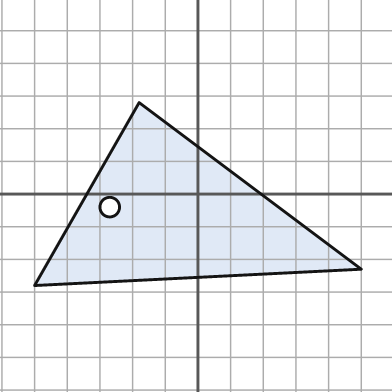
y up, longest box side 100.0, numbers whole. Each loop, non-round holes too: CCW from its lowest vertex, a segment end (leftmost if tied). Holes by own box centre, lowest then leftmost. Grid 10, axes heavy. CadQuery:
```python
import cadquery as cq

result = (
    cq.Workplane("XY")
    .moveTo(-50.0, -28.0)
    .lineTo(50.0, -23.0)
    .lineTo(-18.0, 28.0)
    .close()
    .moveTo(-27.0, -4.0)
    .circle(3.0)
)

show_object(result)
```